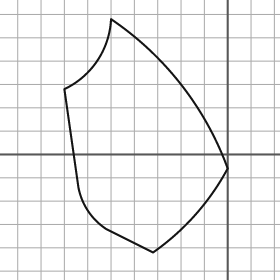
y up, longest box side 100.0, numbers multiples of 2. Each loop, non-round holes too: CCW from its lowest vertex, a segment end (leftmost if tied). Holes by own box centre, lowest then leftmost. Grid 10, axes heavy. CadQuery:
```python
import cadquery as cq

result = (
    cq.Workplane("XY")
    .moveTo(-32.0, -42.0)
    .threePointArc((-14.0, -26.0), (0.0, -6.0))
    .threePointArc((-20.0, 30.0), (-50.0, 58.0))
    .threePointArc((-56.0, 40.0), (-70.0, 28.0))
    .lineTo(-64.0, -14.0)
    .threePointArc((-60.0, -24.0), (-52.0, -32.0))
    .close()
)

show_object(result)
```